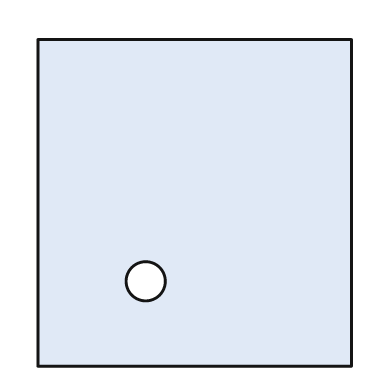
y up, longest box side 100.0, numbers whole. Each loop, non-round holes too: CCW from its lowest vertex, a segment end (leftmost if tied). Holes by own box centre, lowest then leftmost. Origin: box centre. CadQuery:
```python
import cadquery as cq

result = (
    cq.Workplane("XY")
    .moveTo(-48.0, -50.0)
    .lineTo(48.0, -50.0)
    .lineTo(48.0, 50.0)
    .lineTo(-48.0, 50.0)
    .close()
    .moveTo(-15.0, -24.0)
    .circle(6.0)
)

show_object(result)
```